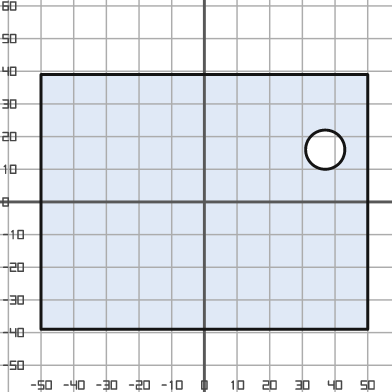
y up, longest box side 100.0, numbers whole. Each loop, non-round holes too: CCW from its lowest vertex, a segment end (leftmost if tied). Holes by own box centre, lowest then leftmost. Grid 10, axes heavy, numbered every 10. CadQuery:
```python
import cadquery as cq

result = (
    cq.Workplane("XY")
    .moveTo(-50.0, -39.0)
    .lineTo(50.0, -39.0)
    .lineTo(50.0, 39.0)
    .lineTo(-50.0, 39.0)
    .close()
    .moveTo(37.0, 16.0)
    .circle(6.0)
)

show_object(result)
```